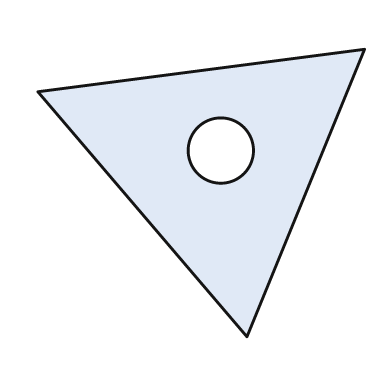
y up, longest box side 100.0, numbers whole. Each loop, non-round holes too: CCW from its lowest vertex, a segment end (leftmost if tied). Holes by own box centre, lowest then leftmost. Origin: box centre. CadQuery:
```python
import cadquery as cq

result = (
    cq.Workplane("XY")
    .moveTo(14.0, -44.0)
    .lineTo(50.0, 44.0)
    .lineTo(-50.0, 31.0)
    .close()
    .moveTo(6.0, 13.0)
    .circle(10.0)
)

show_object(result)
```